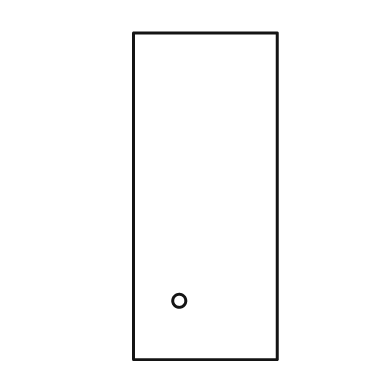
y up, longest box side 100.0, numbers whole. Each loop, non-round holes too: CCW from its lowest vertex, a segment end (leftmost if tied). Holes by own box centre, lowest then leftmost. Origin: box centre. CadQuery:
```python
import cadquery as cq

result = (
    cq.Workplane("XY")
    .moveTo(-22.0, -50.0)
    .lineTo(22.0, -50.0)
    .lineTo(22.0, 50.0)
    .lineTo(-22.0, 50.0)
    .close()
    .moveTo(-8.0, -32.0)
    .circle(2.0)
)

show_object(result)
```